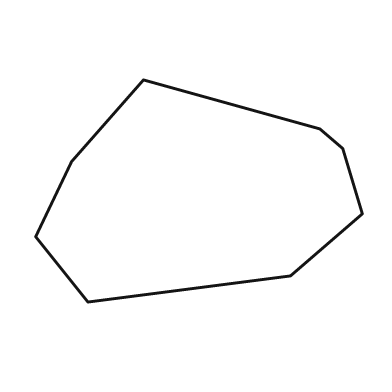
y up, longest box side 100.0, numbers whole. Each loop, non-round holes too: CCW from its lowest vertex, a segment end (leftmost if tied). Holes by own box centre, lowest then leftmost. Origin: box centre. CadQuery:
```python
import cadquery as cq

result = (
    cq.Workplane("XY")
    .moveTo(-34.0, -34.0)
    .lineTo(28.0, -26.0)
    .lineTo(50.0, -7.0)
    .lineTo(44.0, 13.0)
    .lineTo(37.0, 19.0)
    .lineTo(-17.0, 34.0)
    .lineTo(-39.0, 9.0)
    .lineTo(-50.0, -14.0)
    .close()
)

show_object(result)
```